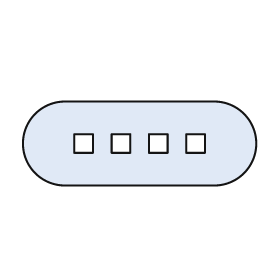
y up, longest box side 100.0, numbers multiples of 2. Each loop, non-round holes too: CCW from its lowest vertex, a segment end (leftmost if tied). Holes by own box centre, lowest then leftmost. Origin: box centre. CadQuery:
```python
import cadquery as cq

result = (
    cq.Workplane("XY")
    .moveTo(-32.0, -18.0)
    .lineTo(32.0, -18.0)
    .threePointArc((50.0, 0.0), (32.0, 18.0))
    .lineTo(-32.0, 18.0)
    .threePointArc((-50.0, 0.0), (-32.0, -18.0))
    .close()
    .moveTo(-28.0, -4.0)
    .lineTo(-20.0, -4.0)
    .lineTo(-20.0, 4.0)
    .lineTo(-28.0, 4.0)
    .close()
    .moveTo(-12.0, -4.0)
    .lineTo(-4.0, -4.0)
    .lineTo(-4.0, 4.0)
    .lineTo(-12.0, 4.0)
    .close()
    .moveTo(4.0, -4.0)
    .lineTo(12.0, -4.0)
    .lineTo(12.0, 4.0)
    .lineTo(4.0, 4.0)
    .close()
    .moveTo(20.0, -4.0)
    .lineTo(28.0, -4.0)
    .lineTo(28.0, 4.0)
    .lineTo(20.0, 4.0)
    .close()
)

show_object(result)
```